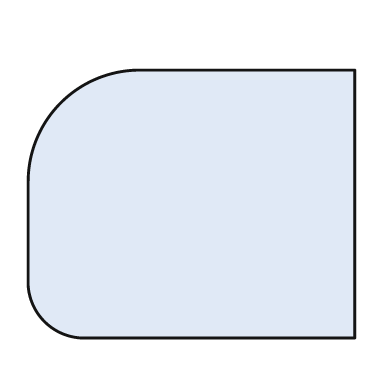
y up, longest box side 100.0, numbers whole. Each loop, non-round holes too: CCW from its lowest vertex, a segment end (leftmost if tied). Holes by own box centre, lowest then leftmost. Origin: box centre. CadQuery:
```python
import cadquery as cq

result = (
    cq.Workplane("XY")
    .moveTo(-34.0, -41.0)
    .lineTo(50.0, -41.0)
    .lineTo(50.0, 41.0)
    .lineTo(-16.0, 41.0)
    .threePointArc((-40.0, 31.0), (-50.0, 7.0))
    .lineTo(-50.0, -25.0)
    .threePointArc((-45.0, -36.0), (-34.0, -41.0))
    .close()
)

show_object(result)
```